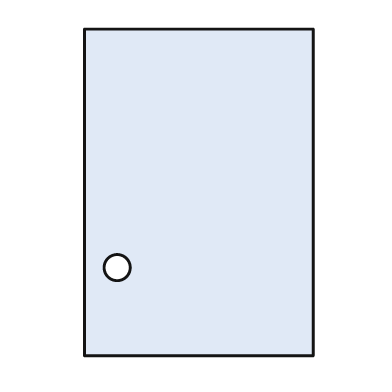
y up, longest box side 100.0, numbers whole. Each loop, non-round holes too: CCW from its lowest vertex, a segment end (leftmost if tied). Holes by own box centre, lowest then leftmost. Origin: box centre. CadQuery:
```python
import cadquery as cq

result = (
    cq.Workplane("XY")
    .moveTo(-35.0, -50.0)
    .lineTo(35.0, -50.0)
    .lineTo(35.0, 50.0)
    .lineTo(-35.0, 50.0)
    .close()
    .moveTo(-25.0, -23.0)
    .circle(4.0)
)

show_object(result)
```